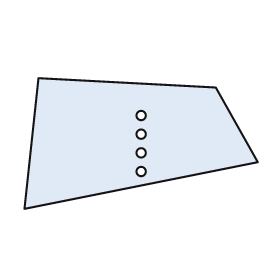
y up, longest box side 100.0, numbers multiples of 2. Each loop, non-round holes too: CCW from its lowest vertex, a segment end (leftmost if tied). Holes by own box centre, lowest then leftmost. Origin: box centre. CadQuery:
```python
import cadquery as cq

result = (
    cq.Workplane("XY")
    .moveTo(-50.0, -28.0)
    .lineTo(50.0, -8.0)
    .lineTo(32.0, 24.0)
    .lineTo(-44.0, 28.0)
    .close()
    .moveTo(0.0, -12.0)
    .circle(2.0)
    .moveTo(0.0, -4.0)
    .circle(2.0)
    .moveTo(0.0, 4.0)
    .circle(2.0)
    .moveTo(0.0, 12.0)
    .circle(2.0)
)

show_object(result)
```